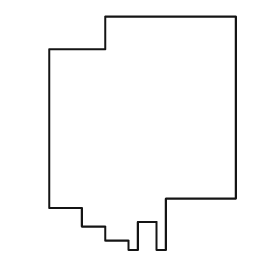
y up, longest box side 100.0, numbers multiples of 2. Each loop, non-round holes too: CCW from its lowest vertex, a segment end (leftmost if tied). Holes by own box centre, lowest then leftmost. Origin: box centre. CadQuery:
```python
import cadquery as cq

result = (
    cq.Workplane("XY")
    .moveTo(-6.0, -50.0)
    .lineTo(-2.0, -50.0)
    .lineTo(-2.0, -38.0)
    .lineTo(6.0, -38.0)
    .lineTo(6.0, -50.0)
    .lineTo(10.0, -50.0)
    .lineTo(10.0, -28.0)
    .lineTo(40.0, -28.0)
    .lineTo(40.0, 50.0)
    .lineTo(-16.0, 50.0)
    .lineTo(-16.0, 36.0)
    .lineTo(-40.0, 36.0)
    .lineTo(-40.0, -32.0)
    .lineTo(-26.0, -32.0)
    .lineTo(-26.0, -40.0)
    .lineTo(-16.0, -40.0)
    .lineTo(-16.0, -46.0)
    .lineTo(-6.0, -46.0)
    .close()
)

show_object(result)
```